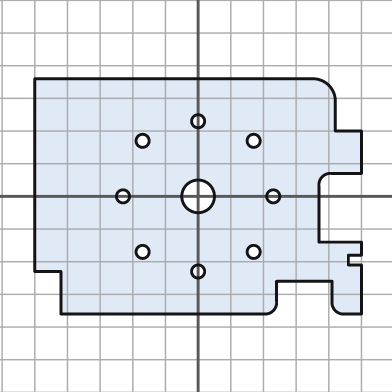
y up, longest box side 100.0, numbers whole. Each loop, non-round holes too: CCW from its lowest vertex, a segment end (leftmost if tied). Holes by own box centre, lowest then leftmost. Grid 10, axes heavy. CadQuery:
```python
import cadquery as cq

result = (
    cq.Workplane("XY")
    .moveTo(-42.0, -36.0)
    .lineTo(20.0, -36.0)
    .threePointArc((23.0, -35.0), (24.0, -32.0))
    .lineTo(24.0, -26.0)
    .lineTo(41.0, -26.0)
    .lineTo(41.0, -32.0)
    .threePointArc((42.0, -35.0), (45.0, -36.0))
    .lineTo(50.0, -36.0)
    .lineTo(50.0, -21.0)
    .lineTo(46.0, -21.0)
    .lineTo(46.0, -18.0)
    .lineTo(50.0, -18.0)
    .lineTo(50.0, -14.0)
    .lineTo(37.0, -14.0)
    .lineTo(37.0, 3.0)
    .threePointArc((38.0, 6.0), (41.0, 7.0))
    .lineTo(50.0, 7.0)
    .lineTo(50.0, 20.0)
    .lineTo(42.0, 20.0)
    .lineTo(42.0, 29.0)
    .threePointArc((40.0, 34.0), (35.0, 36.0))
    .lineTo(-50.0, 36.0)
    .lineTo(-50.0, -23.0)
    .lineTo(-42.0, -23.0)
    .close()
    .moveTo(0.0, -23.0)
    .circle(2.0)
    .moveTo(-17.0, -17.0)
    .circle(2.0)
    .moveTo(17.0, -17.0)
    .circle(2.0)
    .moveTo(-23.0, 0.0)
    .circle(2.0)
    .moveTo(0.0, 0.0)
    .circle(5.0)
    .moveTo(23.0, 0.0)
    .circle(2.0)
    .moveTo(-17.0, 17.0)
    .circle(2.0)
    .moveTo(17.0, 17.0)
    .circle(2.0)
    .moveTo(0.0, 23.0)
    .circle(2.0)
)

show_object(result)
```